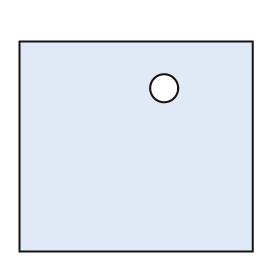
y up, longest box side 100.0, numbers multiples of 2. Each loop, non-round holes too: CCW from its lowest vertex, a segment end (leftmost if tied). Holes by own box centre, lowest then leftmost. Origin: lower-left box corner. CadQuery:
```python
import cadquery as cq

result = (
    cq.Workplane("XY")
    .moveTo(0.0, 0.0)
    .lineTo(100.0, 0.0)
    .lineTo(100.0, 90.0)
    .lineTo(0.0, 90.0)
    .close()
    .moveTo(62.0, 70.0)
    .circle(6.0)
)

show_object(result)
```